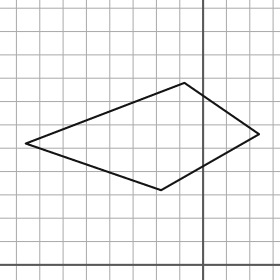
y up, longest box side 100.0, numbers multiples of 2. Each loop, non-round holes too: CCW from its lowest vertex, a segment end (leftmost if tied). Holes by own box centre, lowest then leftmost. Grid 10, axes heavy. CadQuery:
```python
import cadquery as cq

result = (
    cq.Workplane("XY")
    .moveTo(-18.0, 32.0)
    .lineTo(24.0, 56.0)
    .lineTo(-8.0, 78.0)
    .lineTo(-76.0, 52.0)
    .close()
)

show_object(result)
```